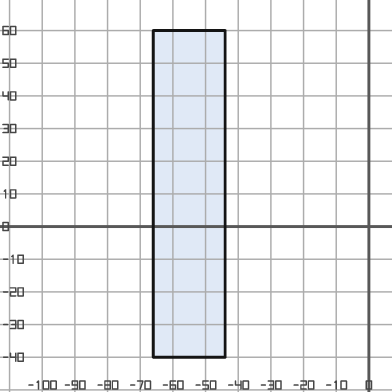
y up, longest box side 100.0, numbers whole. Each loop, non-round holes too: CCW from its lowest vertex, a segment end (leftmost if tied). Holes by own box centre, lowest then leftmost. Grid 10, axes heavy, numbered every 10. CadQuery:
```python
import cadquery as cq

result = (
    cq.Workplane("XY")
    .moveTo(-66.0, -40.0)
    .lineTo(-44.0, -40.0)
    .lineTo(-44.0, 60.0)
    .lineTo(-66.0, 60.0)
    .close()
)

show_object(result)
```